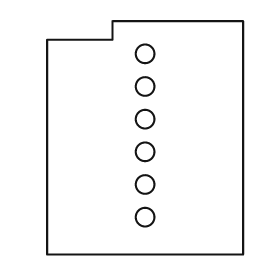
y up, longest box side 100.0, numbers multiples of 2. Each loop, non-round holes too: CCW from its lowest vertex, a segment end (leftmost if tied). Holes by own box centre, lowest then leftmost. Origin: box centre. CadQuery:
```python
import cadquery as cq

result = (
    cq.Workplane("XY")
    .moveTo(-42.0, -50.0)
    .lineTo(42.0, -50.0)
    .lineTo(42.0, 50.0)
    .lineTo(-14.0, 50.0)
    .lineTo(-14.0, 42.0)
    .lineTo(-42.0, 42.0)
    .close()
    .moveTo(0.0, -34.0)
    .circle(4.0)
    .moveTo(0.0, -20.0)
    .circle(4.0)
    .moveTo(0.0, -6.0)
    .circle(4.0)
    .moveTo(0.0, 8.0)
    .circle(4.0)
    .moveTo(0.0, 22.0)
    .circle(4.0)
    .moveTo(0.0, 36.0)
    .circle(4.0)
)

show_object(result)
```